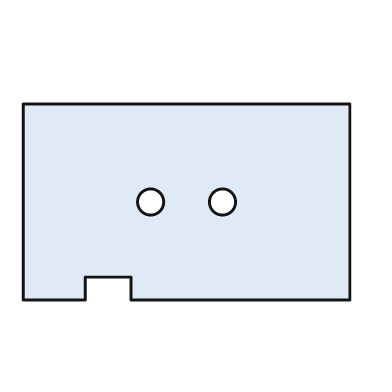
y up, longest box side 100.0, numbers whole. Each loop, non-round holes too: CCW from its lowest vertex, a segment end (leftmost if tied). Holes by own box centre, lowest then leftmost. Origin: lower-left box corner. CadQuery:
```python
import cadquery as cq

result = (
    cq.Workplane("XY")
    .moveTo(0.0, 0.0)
    .lineTo(19.0, 0.0)
    .lineTo(19.0, 7.0)
    .lineTo(33.0, 7.0)
    .lineTo(33.0, 0.0)
    .lineTo(100.0, 0.0)
    .lineTo(100.0, 60.0)
    .lineTo(0.0, 60.0)
    .close()
    .moveTo(39.0, 30.0)
    .circle(4.0)
    .moveTo(61.0, 30.0)
    .circle(4.0)
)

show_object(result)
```